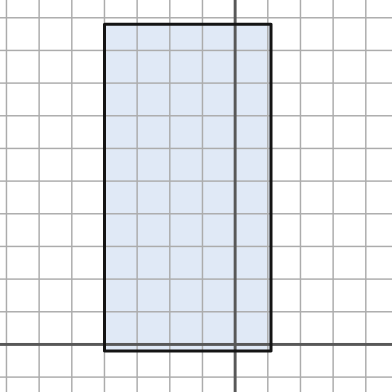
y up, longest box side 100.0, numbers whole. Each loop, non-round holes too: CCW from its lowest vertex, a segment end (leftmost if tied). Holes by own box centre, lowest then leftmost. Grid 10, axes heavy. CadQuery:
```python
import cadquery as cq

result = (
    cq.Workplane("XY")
    .moveTo(-40.0, -2.0)
    .lineTo(11.0, -2.0)
    .lineTo(11.0, 98.0)
    .lineTo(-40.0, 98.0)
    .close()
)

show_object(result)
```